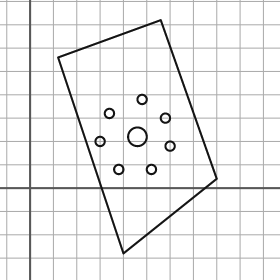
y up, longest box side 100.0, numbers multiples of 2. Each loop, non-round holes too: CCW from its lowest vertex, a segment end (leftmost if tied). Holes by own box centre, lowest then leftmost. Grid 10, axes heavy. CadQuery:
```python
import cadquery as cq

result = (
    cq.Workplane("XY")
    .moveTo(40.0, -28.0)
    .lineTo(80.0, 4.0)
    .lineTo(56.0, 72.0)
    .lineTo(12.0, 56.0)
    .close()
    .moveTo(38.0, 8.0)
    .circle(2.0)
    .moveTo(52.0, 8.0)
    .circle(2.0)
    .moveTo(60.0, 18.0)
    .circle(2.0)
    .moveTo(30.0, 20.0)
    .circle(2.0)
    .moveTo(46.0, 22.0)
    .circle(4.0)
    .moveTo(58.0, 30.0)
    .circle(2.0)
    .moveTo(34.0, 32.0)
    .circle(2.0)
    .moveTo(48.0, 38.0)
    .circle(2.0)
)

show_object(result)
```